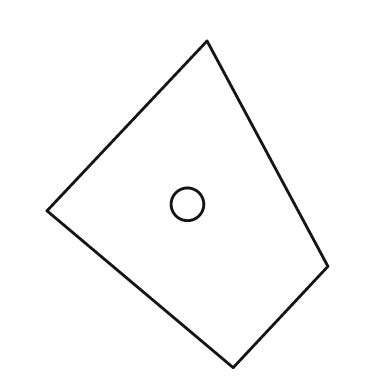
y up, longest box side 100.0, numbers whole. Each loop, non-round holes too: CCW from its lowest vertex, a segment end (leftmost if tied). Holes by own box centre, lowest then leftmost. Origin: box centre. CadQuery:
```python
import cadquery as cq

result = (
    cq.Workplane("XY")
    .moveTo(14.0, -50.0)
    .lineTo(43.0, -19.0)
    .lineTo(6.0, 50.0)
    .lineTo(-43.0, -2.0)
    .close()
    .moveTo(0.0, 0.0)
    .circle(5.0)
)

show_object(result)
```